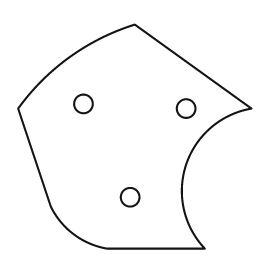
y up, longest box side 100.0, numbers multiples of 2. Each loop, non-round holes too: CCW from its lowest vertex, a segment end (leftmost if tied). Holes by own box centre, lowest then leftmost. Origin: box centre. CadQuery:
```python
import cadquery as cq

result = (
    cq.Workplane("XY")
    .moveTo(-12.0, -48.0)
    .lineTo(30.0, -48.0)
    .threePointArc((22.0, -12.0), (50.0, 12.0))
    .lineTo(0.0, 48.0)
    .threePointArc((-28.0, 34.0), (-50.0, 12.0))
    .lineTo(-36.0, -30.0)
    .threePointArc((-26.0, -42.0), (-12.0, -48.0))
    .close()
    .moveTo(-2.0, -26.0)
    .circle(4.0)
    .moveTo(22.0, 12.0)
    .circle(4.0)
    .moveTo(-22.0, 14.0)
    .circle(4.0)
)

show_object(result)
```